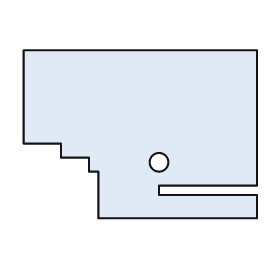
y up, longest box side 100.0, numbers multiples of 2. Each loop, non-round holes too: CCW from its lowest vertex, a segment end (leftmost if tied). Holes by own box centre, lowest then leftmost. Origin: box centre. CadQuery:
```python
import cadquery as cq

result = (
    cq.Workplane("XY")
    .moveTo(-18.0, -36.0)
    .lineTo(50.0, -36.0)
    .lineTo(50.0, -26.0)
    .lineTo(8.0, -26.0)
    .lineTo(8.0, -22.0)
    .lineTo(50.0, -22.0)
    .lineTo(50.0, 36.0)
    .lineTo(-50.0, 36.0)
    .lineTo(-50.0, -4.0)
    .lineTo(-34.0, -4.0)
    .lineTo(-34.0, -10.0)
    .lineTo(-22.0, -10.0)
    .lineTo(-22.0, -16.0)
    .lineTo(-18.0, -16.0)
    .close()
    .moveTo(8.0, -12.0)
    .circle(4.0)
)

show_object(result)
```